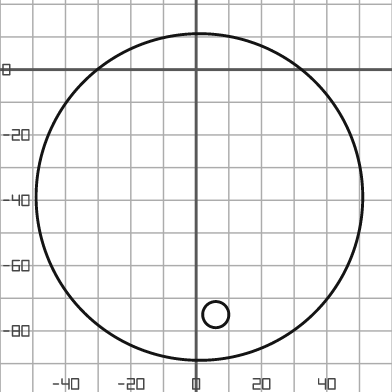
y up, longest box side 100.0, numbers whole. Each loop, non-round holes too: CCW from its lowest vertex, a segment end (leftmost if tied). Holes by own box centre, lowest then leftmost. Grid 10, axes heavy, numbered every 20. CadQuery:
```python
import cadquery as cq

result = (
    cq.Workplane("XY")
    .moveTo(1.0, -39.0)
    .circle(50.0)
    .moveTo(6.0, -75.0)
    .circle(4.0)
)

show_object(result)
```